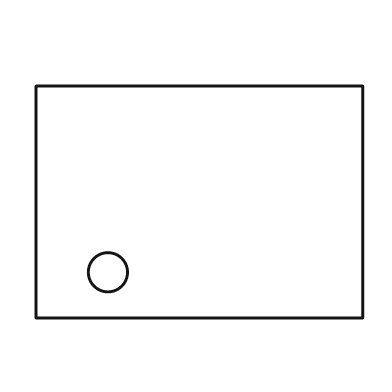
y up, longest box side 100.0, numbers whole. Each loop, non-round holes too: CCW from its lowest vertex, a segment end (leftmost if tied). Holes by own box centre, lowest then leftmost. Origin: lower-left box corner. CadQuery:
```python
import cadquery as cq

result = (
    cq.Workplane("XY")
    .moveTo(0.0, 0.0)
    .lineTo(100.0, 0.0)
    .lineTo(100.0, 71.0)
    .lineTo(0.0, 71.0)
    .close()
    .moveTo(22.0, 14.0)
    .circle(6.0)
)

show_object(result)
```